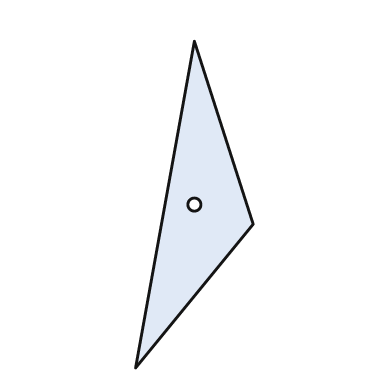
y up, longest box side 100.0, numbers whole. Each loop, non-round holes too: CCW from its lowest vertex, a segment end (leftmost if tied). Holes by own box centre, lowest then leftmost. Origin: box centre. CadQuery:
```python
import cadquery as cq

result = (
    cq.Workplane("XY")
    .moveTo(-18.0, -50.0)
    .lineTo(18.0, -6.0)
    .lineTo(0.0, 50.0)
    .close()
    .moveTo(0.0, 0.0)
    .circle(2.0)
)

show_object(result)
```